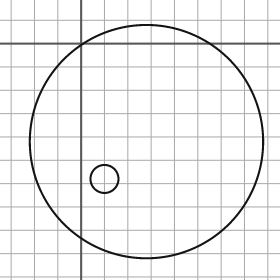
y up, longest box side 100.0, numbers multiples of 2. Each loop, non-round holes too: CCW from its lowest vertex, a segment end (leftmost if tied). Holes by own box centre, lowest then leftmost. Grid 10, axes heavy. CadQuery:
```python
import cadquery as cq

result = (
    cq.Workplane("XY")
    .moveTo(28.0, -42.0)
    .circle(50.0)
    .moveTo(10.0, -58.0)
    .circle(6.0)
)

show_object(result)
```